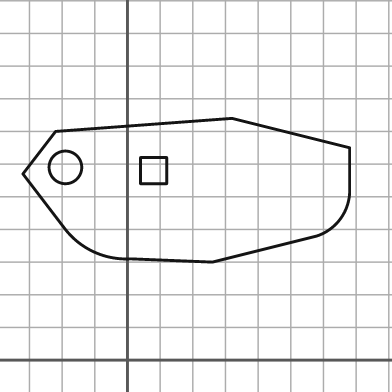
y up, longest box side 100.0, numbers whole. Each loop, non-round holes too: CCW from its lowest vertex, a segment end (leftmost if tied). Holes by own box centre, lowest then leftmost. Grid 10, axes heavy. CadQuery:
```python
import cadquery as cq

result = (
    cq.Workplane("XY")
    .moveTo(26.0, 30.0)
    .lineTo(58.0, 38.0)
    .threePointArc((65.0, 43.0), (68.0, 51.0))
    .lineTo(68.0, 65.0)
    .lineTo(32.0, 74.0)
    .lineTo(-22.0, 70.0)
    .lineTo(-32.0, 57.0)
    .lineTo(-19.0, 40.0)
    .threePointArc((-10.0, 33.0), (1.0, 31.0))
    .close()
    .moveTo(4.0, 54.0)
    .lineTo(12.0, 54.0)
    .lineTo(12.0, 62.0)
    .lineTo(4.0, 62.0)
    .close()
    .moveTo(-19.0, 59.0)
    .circle(5.0)
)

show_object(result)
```